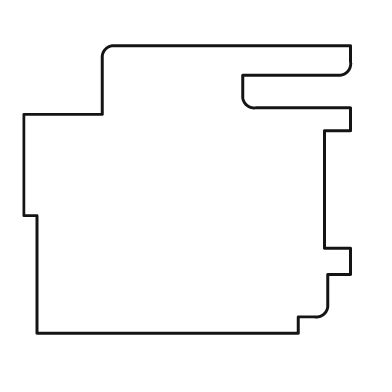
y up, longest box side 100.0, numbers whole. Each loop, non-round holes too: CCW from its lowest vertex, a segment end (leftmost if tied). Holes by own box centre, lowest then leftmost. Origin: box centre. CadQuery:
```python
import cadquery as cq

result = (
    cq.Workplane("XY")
    .moveTo(-46.0, -44.0)
    .lineTo(34.0, -44.0)
    .lineTo(34.0, -39.0)
    .lineTo(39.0, -39.0)
    .threePointArc((42.0, -38.0), (43.0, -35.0))
    .lineTo(43.0, -26.0)
    .lineTo(50.0, -26.0)
    .lineTo(50.0, -18.0)
    .lineTo(42.0, -18.0)
    .lineTo(42.0, 18.0)
    .lineTo(50.0, 18.0)
    .lineTo(50.0, 25.0)
    .lineTo(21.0, 25.0)
    .threePointArc((18.0, 26.0), (17.0, 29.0))
    .lineTo(17.0, 35.0)
    .lineTo(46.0, 35.0)
    .threePointArc((49.0, 36.0), (50.0, 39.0))
    .lineTo(50.0, 44.0)
    .lineTo(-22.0, 44.0)
    .threePointArc((-25.0, 43.0), (-26.0, 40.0))
    .lineTo(-26.0, 23.0)
    .lineTo(-50.0, 23.0)
    .lineTo(-50.0, -8.0)
    .lineTo(-46.0, -8.0)
    .close()
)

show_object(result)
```